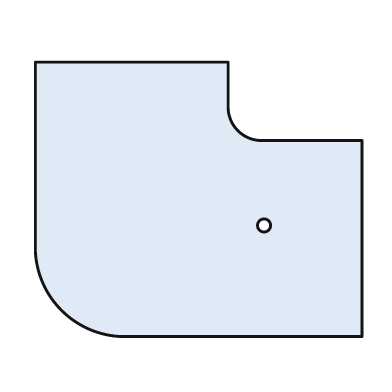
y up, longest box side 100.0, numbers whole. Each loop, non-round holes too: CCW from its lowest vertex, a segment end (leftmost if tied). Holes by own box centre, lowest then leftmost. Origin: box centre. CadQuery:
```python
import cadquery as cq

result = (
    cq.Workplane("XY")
    .moveTo(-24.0, -42.0)
    .lineTo(50.0, -42.0)
    .lineTo(50.0, 18.0)
    .lineTo(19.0, 18.0)
    .threePointArc((12.0, 21.0), (9.0, 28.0))
    .lineTo(9.0, 42.0)
    .lineTo(-50.0, 42.0)
    .lineTo(-50.0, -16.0)
    .threePointArc((-42.0, -34.0), (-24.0, -42.0))
    .close()
    .moveTo(20.0, -8.0)
    .circle(2.0)
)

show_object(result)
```